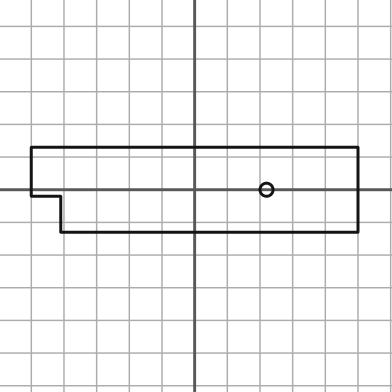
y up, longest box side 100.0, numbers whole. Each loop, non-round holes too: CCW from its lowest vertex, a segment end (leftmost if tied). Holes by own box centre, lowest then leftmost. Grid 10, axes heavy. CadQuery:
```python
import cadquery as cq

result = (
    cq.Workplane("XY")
    .moveTo(-41.0, -13.0)
    .lineTo(50.0, -13.0)
    .lineTo(50.0, 13.0)
    .lineTo(-50.0, 13.0)
    .lineTo(-50.0, -2.0)
    .lineTo(-41.0, -2.0)
    .close()
    .moveTo(22.0, 0.0)
    .circle(2.0)
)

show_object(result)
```